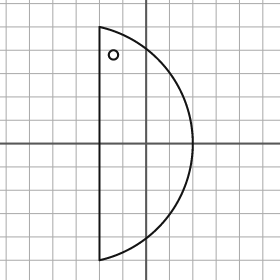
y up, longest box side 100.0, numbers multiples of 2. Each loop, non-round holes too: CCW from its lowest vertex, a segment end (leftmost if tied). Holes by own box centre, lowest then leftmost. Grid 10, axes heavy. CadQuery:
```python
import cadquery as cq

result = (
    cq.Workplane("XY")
    .moveTo(-20.0, -50.0)
    .threePointArc((20.0, 0.0), (-20.0, 50.0))
    .close()
    .moveTo(-14.0, 38.0)
    .circle(2.0)
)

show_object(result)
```